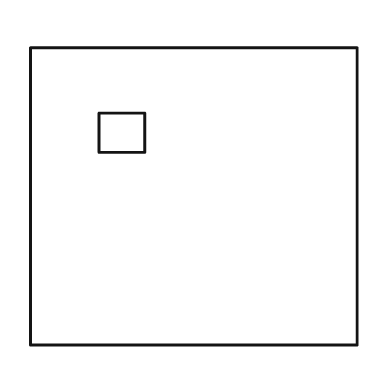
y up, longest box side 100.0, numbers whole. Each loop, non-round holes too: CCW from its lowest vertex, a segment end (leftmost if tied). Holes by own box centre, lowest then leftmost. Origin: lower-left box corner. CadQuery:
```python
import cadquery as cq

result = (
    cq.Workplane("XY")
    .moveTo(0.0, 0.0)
    .lineTo(100.0, 0.0)
    .lineTo(100.0, 91.0)
    .lineTo(0.0, 91.0)
    .close()
    .moveTo(21.0, 59.0)
    .lineTo(35.0, 59.0)
    .lineTo(35.0, 71.0)
    .lineTo(21.0, 71.0)
    .close()
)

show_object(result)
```